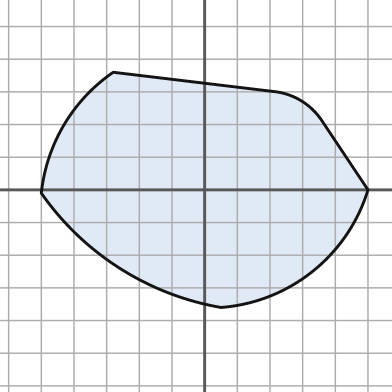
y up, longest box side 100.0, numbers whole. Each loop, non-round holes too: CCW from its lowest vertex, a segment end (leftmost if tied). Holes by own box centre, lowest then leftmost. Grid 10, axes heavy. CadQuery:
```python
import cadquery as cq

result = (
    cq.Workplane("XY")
    .moveTo(5.0, -36.0)
    .threePointArc((33.0, -25.0), (50.0, 0.0))
    .lineTo(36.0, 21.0)
    .threePointArc((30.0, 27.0), (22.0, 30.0))
    .lineTo(-28.0, 36.0)
    .threePointArc((-43.0, 20.0), (-50.0, -1.0))
    .threePointArc((-26.0, -24.0), (5.0, -36.0))
    .close()
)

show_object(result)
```